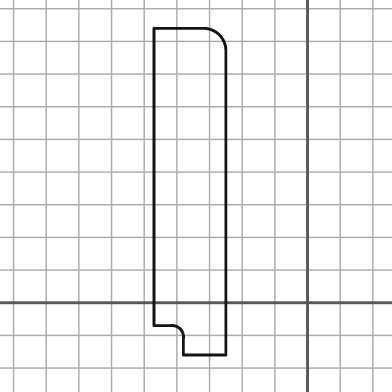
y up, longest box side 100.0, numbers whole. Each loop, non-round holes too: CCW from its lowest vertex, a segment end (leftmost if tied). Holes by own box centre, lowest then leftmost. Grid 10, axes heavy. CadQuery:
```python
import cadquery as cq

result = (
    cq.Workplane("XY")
    .moveTo(-38.0, -16.0)
    .lineTo(-25.0, -16.0)
    .lineTo(-25.0, 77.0)
    .threePointArc((-27.0, 82.0), (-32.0, 84.0))
    .lineTo(-47.0, 84.0)
    .lineTo(-47.0, -7.0)
    .lineTo(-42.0, -7.0)
    .threePointArc((-39.0, -8.0), (-38.0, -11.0))
    .close()
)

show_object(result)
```